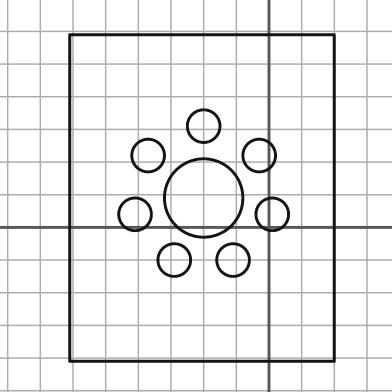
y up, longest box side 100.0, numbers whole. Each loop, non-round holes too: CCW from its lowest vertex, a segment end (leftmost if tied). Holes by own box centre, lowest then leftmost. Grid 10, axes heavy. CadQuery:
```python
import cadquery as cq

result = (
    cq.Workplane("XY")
    .moveTo(-61.0, -41.0)
    .lineTo(20.0, -41.0)
    .lineTo(20.0, 59.0)
    .lineTo(-61.0, 59.0)
    .close()
    .moveTo(-29.0, -10.0)
    .circle(5.0)
    .moveTo(-11.0, -10.0)
    .circle(5.0)
    .moveTo(-41.0, 4.0)
    .circle(5.0)
    .moveTo(1.0, 4.0)
    .circle(5.0)
    .moveTo(-20.0, 9.0)
    .circle(12.0)
    .moveTo(-37.0, 22.0)
    .circle(5.0)
    .moveTo(-3.0, 22.0)
    .circle(5.0)
    .moveTo(-20.0, 31.0)
    .circle(5.0)
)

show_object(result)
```